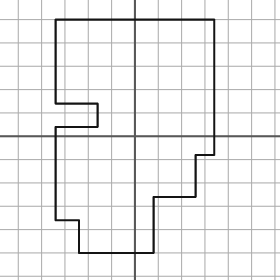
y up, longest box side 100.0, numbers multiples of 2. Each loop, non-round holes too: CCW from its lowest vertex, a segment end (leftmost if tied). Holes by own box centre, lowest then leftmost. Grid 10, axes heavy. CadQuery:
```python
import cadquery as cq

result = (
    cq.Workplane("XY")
    .moveTo(-24.0, -50.0)
    .lineTo(8.0, -50.0)
    .lineTo(8.0, -26.0)
    .lineTo(26.0, -26.0)
    .lineTo(26.0, -8.0)
    .lineTo(34.0, -8.0)
    .lineTo(34.0, 50.0)
    .lineTo(-34.0, 50.0)
    .lineTo(-34.0, 14.0)
    .lineTo(-16.0, 14.0)
    .lineTo(-16.0, 4.0)
    .lineTo(-34.0, 4.0)
    .lineTo(-34.0, -36.0)
    .lineTo(-24.0, -36.0)
    .close()
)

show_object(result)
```